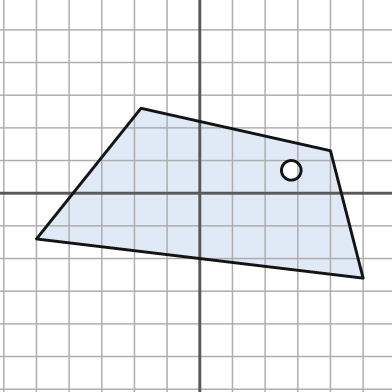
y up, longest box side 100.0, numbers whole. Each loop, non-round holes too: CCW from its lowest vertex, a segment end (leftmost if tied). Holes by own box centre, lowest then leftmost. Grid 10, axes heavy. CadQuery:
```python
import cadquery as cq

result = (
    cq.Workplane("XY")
    .moveTo(50.0, -26.0)
    .lineTo(40.0, 13.0)
    .lineTo(-18.0, 26.0)
    .lineTo(-50.0, -14.0)
    .close()
    .moveTo(28.0, 7.0)
    .circle(3.0)
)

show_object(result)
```